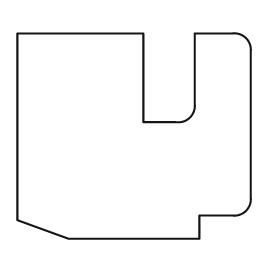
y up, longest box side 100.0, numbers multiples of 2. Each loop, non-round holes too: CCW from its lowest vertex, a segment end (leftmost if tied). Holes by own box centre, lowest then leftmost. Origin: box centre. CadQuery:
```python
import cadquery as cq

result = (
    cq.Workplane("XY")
    .moveTo(-28.0, -44.0)
    .lineTo(28.0, -44.0)
    .lineTo(28.0, -34.0)
    .lineTo(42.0, -34.0)
    .threePointArc((48.0, -32.0), (50.0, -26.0))
    .lineTo(50.0, 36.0)
    .threePointArc((48.0, 42.0), (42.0, 44.0))
    .lineTo(26.0, 44.0)
    .lineTo(26.0, 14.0)
    .threePointArc((24.0, 8.0), (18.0, 6.0))
    .lineTo(4.0, 6.0)
    .lineTo(4.0, 44.0)
    .lineTo(-50.0, 44.0)
    .lineTo(-50.0, -36.0)
    .close()
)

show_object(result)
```